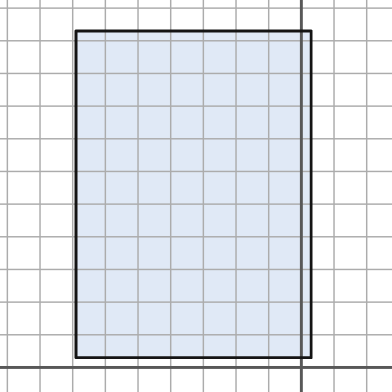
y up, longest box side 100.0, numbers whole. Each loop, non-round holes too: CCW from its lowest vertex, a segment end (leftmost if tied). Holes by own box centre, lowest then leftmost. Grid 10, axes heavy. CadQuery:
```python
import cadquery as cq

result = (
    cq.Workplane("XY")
    .moveTo(-69.0, 3.0)
    .lineTo(3.0, 3.0)
    .lineTo(3.0, 103.0)
    .lineTo(-69.0, 103.0)
    .close()
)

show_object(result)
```